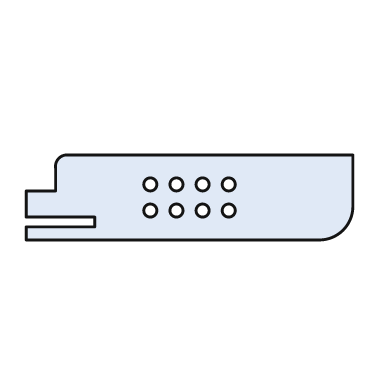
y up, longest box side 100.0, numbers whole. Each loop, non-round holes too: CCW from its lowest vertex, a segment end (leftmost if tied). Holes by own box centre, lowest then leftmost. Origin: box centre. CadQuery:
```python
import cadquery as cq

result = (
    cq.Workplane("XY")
    .moveTo(-50.0, -13.0)
    .lineTo(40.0, -13.0)
    .threePointArc((47.0, -10.0), (50.0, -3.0))
    .lineTo(50.0, 13.0)
    .lineTo(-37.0, 13.0)
    .threePointArc((-40.0, 12.0), (-41.0, 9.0))
    .lineTo(-41.0, 2.0)
    .lineTo(-50.0, 2.0)
    .lineTo(-50.0, -6.0)
    .lineTo(-29.0, -6.0)
    .lineTo(-29.0, -9.0)
    .lineTo(-50.0, -9.0)
    .close()
    .moveTo(-12.0, -4.0)
    .circle(2.0)
    .moveTo(-4.0, -4.0)
    .circle(2.0)
    .moveTo(4.0, -4.0)
    .circle(2.0)
    .moveTo(12.0, -4.0)
    .circle(2.0)
    .moveTo(-12.0, 4.0)
    .circle(2.0)
    .moveTo(-4.0, 4.0)
    .circle(2.0)
    .moveTo(4.0, 4.0)
    .circle(2.0)
    .moveTo(12.0, 4.0)
    .circle(2.0)
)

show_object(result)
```